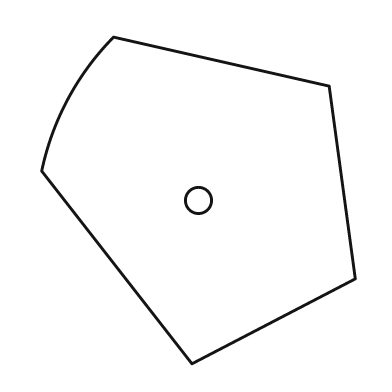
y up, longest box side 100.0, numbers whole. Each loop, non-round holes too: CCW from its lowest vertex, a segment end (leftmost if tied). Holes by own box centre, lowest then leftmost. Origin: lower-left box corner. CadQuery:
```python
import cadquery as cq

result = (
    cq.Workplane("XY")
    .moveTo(46.0, 0.0)
    .lineTo(96.0, 26.0)
    .lineTo(88.0, 85.0)
    .lineTo(22.0, 100.0)
    .threePointArc((8.0, 81.0), (0.0, 59.0))
    .close()
    .moveTo(48.0, 50.0)
    .circle(4.0)
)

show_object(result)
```